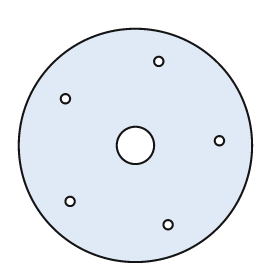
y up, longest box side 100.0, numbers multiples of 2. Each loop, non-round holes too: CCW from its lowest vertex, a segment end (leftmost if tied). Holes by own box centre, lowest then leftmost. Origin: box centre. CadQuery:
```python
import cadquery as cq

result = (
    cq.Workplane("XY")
    .moveTo(0.0, 0.0)
    .circle(50.0)
    .moveTo(14.0, -34.0)
    .circle(2.0)
    .moveTo(-28.0, -24.0)
    .circle(2.0)
    .moveTo(0.0, 0.0)
    .circle(8.0)
    .moveTo(36.0, 2.0)
    .circle(2.0)
    .moveTo(-30.0, 20.0)
    .circle(2.0)
    .moveTo(10.0, 36.0)
    .circle(2.0)
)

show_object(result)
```